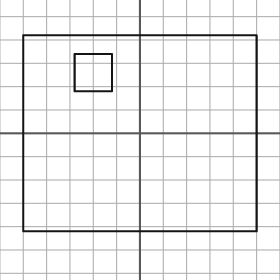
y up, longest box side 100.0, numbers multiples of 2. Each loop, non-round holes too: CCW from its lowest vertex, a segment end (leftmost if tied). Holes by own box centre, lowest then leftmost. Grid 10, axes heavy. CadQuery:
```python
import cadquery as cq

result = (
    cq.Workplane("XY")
    .moveTo(-50.0, -42.0)
    .lineTo(50.0, -42.0)
    .lineTo(50.0, 42.0)
    .lineTo(-50.0, 42.0)
    .close()
    .moveTo(-28.0, 18.0)
    .lineTo(-12.0, 18.0)
    .lineTo(-12.0, 34.0)
    .lineTo(-28.0, 34.0)
    .close()
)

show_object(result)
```